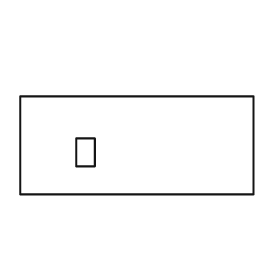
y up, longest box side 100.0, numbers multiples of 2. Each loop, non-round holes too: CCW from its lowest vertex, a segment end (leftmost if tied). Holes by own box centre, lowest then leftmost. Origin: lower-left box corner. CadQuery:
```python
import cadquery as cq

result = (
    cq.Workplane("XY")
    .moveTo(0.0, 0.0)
    .lineTo(100.0, 0.0)
    .lineTo(100.0, 42.0)
    .lineTo(0.0, 42.0)
    .close()
    .moveTo(24.0, 12.0)
    .lineTo(32.0, 12.0)
    .lineTo(32.0, 24.0)
    .lineTo(24.0, 24.0)
    .close()
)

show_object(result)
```